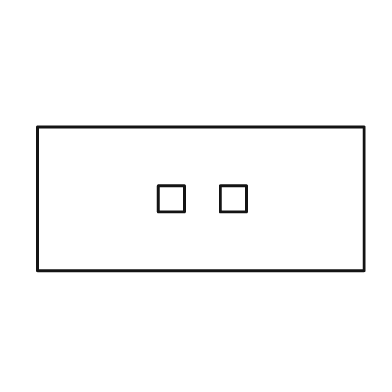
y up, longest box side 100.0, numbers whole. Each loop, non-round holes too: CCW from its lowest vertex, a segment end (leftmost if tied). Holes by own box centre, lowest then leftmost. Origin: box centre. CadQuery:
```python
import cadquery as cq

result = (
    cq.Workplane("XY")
    .moveTo(-50.0, -22.0)
    .lineTo(50.0, -22.0)
    .lineTo(50.0, 22.0)
    .lineTo(-50.0, 22.0)
    .close()
    .moveTo(-13.0, -4.0)
    .lineTo(-5.0, -4.0)
    .lineTo(-5.0, 4.0)
    .lineTo(-13.0, 4.0)
    .close()
    .moveTo(6.0, -4.0)
    .lineTo(14.0, -4.0)
    .lineTo(14.0, 4.0)
    .lineTo(6.0, 4.0)
    .close()
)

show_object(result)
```